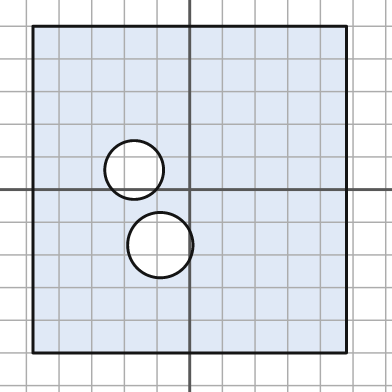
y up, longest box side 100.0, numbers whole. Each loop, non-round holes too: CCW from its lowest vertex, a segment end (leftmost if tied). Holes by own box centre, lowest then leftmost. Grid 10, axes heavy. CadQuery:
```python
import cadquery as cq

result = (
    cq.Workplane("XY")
    .moveTo(-48.0, -50.0)
    .lineTo(48.0, -50.0)
    .lineTo(48.0, 50.0)
    .lineTo(-48.0, 50.0)
    .close()
    .moveTo(-9.0, -17.0)
    .circle(10.0)
    .moveTo(-17.0, 6.0)
    .circle(9.0)
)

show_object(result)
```